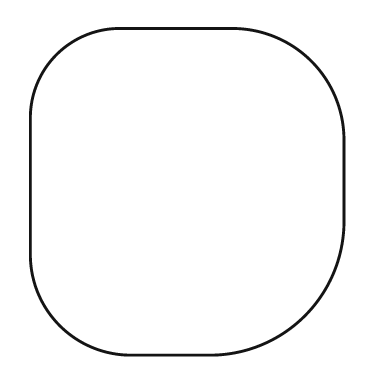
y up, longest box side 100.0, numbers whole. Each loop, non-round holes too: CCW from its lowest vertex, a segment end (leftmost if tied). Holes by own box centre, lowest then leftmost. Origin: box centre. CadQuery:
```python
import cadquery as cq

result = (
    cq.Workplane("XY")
    .moveTo(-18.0, -50.0)
    .lineTo(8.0, -50.0)
    .threePointArc((36.0, -38.0), (48.0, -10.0))
    .lineTo(48.0, 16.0)
    .threePointArc((38.0, 40.0), (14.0, 50.0))
    .lineTo(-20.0, 50.0)
    .threePointArc((-40.0, 42.0), (-48.0, 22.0))
    .lineTo(-48.0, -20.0)
    .threePointArc((-39.0, -41.0), (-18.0, -50.0))
    .close()
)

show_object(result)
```